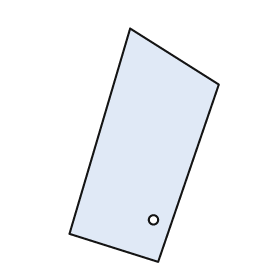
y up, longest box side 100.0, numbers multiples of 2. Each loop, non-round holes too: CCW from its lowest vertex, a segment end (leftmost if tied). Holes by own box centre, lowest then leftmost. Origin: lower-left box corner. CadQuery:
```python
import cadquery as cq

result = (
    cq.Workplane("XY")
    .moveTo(38.0, 0.0)
    .lineTo(64.0, 76.0)
    .lineTo(26.0, 100.0)
    .lineTo(0.0, 12.0)
    .close()
    .moveTo(36.0, 18.0)
    .circle(2.0)
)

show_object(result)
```